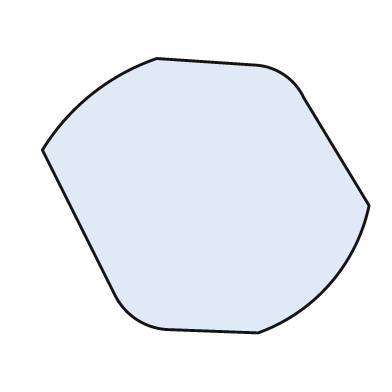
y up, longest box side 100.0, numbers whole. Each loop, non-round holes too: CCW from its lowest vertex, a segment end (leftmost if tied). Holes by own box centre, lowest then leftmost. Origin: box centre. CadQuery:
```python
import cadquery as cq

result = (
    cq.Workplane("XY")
    .moveTo(16.0, -42.0)
    .threePointArc((38.0, -27.0), (50.0, -3.0))
    .lineTo(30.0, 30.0)
    .threePointArc((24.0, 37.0), (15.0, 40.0))
    .lineTo(-15.0, 42.0)
    .threePointArc((-35.0, 31.0), (-50.0, 14.0))
    .lineTo(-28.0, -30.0)
    .threePointArc((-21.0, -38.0), (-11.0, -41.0))
    .close()
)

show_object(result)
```